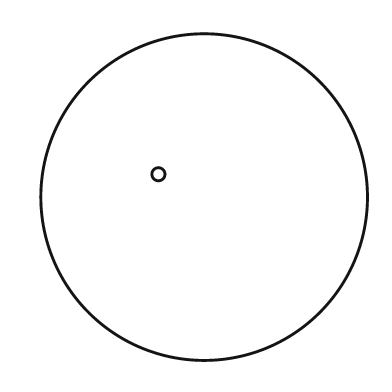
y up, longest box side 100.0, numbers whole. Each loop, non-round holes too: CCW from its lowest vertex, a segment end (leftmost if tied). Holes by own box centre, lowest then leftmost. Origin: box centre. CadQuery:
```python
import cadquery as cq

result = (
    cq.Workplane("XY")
    .moveTo(0.0, 0.0)
    .circle(50.0)
    .moveTo(-14.0, 7.0)
    .circle(2.0)
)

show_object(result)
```